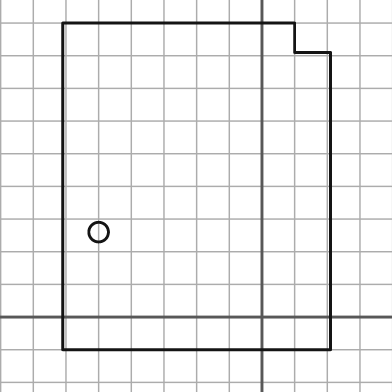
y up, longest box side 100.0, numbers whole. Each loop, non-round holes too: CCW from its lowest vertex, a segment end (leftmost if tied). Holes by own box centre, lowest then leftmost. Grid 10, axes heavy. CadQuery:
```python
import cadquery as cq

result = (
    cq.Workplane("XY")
    .moveTo(-61.0, -10.0)
    .lineTo(21.0, -10.0)
    .lineTo(21.0, 81.0)
    .lineTo(10.0, 81.0)
    .lineTo(10.0, 90.0)
    .lineTo(-61.0, 90.0)
    .close()
    .moveTo(-50.0, 26.0)
    .circle(3.0)
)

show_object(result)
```